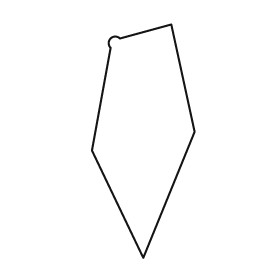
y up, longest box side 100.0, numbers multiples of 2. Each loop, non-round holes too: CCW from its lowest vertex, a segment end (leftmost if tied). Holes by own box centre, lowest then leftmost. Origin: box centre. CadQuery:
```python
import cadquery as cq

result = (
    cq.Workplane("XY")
    .moveTo(0.0, -50.0)
    .lineTo(22.0, 4.0)
    .lineTo(12.0, 50.0)
    .lineTo(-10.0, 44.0)
    .threePointArc((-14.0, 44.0), (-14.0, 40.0))
    .lineTo(-22.0, -4.0)
    .close()
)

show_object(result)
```